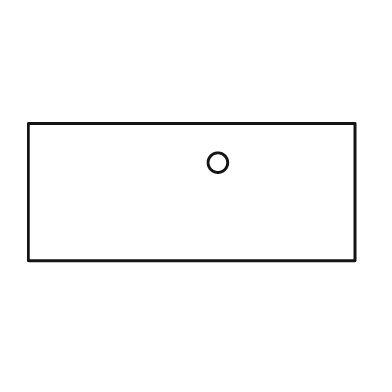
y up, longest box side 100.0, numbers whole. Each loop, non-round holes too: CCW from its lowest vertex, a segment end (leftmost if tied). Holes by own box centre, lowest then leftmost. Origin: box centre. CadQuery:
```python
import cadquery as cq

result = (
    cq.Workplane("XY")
    .moveTo(-50.0, -21.0)
    .lineTo(50.0, -21.0)
    .lineTo(50.0, 21.0)
    .lineTo(-50.0, 21.0)
    .close()
    .moveTo(8.0, 9.0)
    .circle(3.0)
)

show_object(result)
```